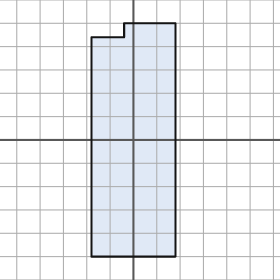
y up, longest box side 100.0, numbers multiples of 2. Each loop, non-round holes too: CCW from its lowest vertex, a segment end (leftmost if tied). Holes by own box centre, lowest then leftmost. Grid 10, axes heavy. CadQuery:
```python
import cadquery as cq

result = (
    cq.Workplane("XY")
    .moveTo(-18.0, -50.0)
    .lineTo(18.0, -50.0)
    .lineTo(18.0, 50.0)
    .lineTo(-4.0, 50.0)
    .lineTo(-4.0, 44.0)
    .lineTo(-18.0, 44.0)
    .close()
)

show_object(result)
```